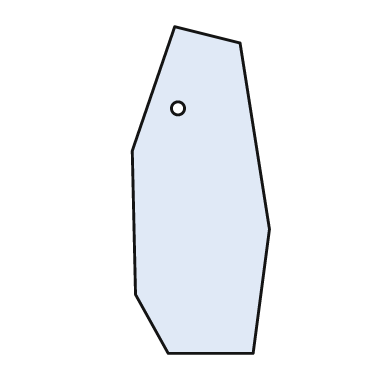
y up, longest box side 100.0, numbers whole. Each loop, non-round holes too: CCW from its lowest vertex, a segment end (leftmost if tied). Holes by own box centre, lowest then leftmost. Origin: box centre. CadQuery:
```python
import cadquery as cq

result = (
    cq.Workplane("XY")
    .moveTo(-10.0, -50.0)
    .lineTo(16.0, -50.0)
    .lineTo(21.0, -12.0)
    .lineTo(12.0, 45.0)
    .lineTo(-8.0, 50.0)
    .lineTo(-21.0, 12.0)
    .lineTo(-20.0, -32.0)
    .close()
    .moveTo(-7.0, 25.0)
    .circle(2.0)
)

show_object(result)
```